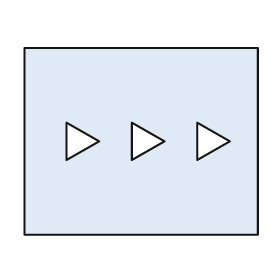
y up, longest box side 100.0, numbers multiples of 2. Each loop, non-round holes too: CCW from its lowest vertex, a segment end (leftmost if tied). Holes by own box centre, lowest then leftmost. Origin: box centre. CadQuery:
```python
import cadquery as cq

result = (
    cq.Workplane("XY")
    .moveTo(-50.0, -40.0)
    .lineTo(50.0, -40.0)
    .lineTo(50.0, 40.0)
    .lineTo(-50.0, 40.0)
    .close()
    .moveTo(-32.0, -8.0)
    .lineTo(-18.0, 0.0)
    .lineTo(-32.0, 8.0)
    .close()
    .moveTo(-4.0, -8.0)
    .lineTo(10.0, 0.0)
    .lineTo(-4.0, 8.0)
    .close()
    .moveTo(24.0, -8.0)
    .lineTo(38.0, 0.0)
    .lineTo(24.0, 8.0)
    .close()
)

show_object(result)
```